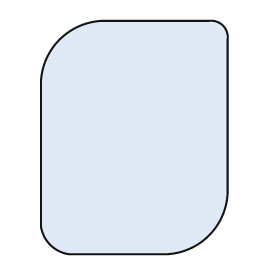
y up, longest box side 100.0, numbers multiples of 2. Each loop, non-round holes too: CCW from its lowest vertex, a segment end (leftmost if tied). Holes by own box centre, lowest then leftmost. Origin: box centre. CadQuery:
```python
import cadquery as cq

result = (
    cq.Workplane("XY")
    .moveTo(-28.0, -50.0)
    .lineTo(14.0, -50.0)
    .threePointArc((32.0, -42.0), (40.0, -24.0))
    .lineTo(40.0, 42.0)
    .threePointArc((38.0, 48.0), (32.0, 50.0))
    .lineTo(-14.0, 50.0)
    .threePointArc((-32.0, 42.0), (-40.0, 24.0))
    .lineTo(-40.0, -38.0)
    .threePointArc((-36.0, -46.0), (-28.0, -50.0))
    .close()
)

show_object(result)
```